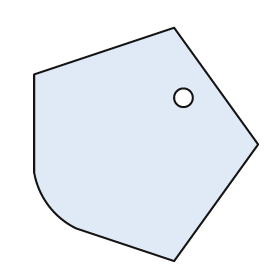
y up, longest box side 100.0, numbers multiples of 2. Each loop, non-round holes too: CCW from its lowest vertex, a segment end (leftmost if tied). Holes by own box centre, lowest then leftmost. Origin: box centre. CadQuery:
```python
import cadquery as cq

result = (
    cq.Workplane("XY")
    .moveTo(12.0, -50.0)
    .lineTo(48.0, 0.0)
    .lineTo(12.0, 50.0)
    .lineTo(-48.0, 30.0)
    .lineTo(-48.0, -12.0)
    .threePointArc((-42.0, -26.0), (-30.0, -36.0))
    .close()
    .moveTo(16.0, 20.0)
    .circle(4.0)
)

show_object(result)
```